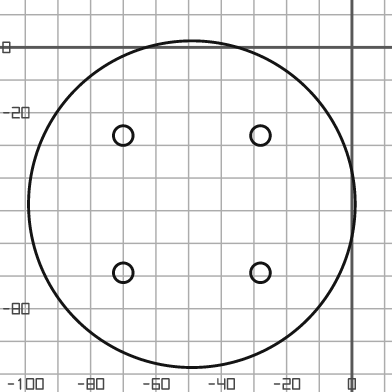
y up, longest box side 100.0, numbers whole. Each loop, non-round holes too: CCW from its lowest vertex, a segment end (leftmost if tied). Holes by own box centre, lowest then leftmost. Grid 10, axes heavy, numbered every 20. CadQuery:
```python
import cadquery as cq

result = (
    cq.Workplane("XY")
    .moveTo(-49.0, -48.0)
    .circle(50.0)
    .moveTo(-70.0, -69.0)
    .circle(3.0)
    .moveTo(-28.0, -69.0)
    .circle(3.0)
    .moveTo(-70.0, -27.0)
    .circle(3.0)
    .moveTo(-28.0, -27.0)
    .circle(3.0)
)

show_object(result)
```